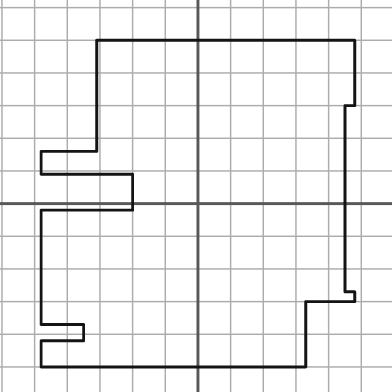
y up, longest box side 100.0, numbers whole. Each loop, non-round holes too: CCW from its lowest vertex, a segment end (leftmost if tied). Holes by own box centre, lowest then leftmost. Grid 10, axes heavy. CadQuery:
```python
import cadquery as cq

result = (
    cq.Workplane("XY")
    .moveTo(-48.0, -50.0)
    .lineTo(33.0, -50.0)
    .lineTo(33.0, -30.0)
    .lineTo(48.0, -30.0)
    .lineTo(48.0, -27.0)
    .lineTo(45.0, -27.0)
    .lineTo(45.0, 30.0)
    .lineTo(48.0, 30.0)
    .lineTo(48.0, 50.0)
    .lineTo(-31.0, 50.0)
    .lineTo(-31.0, 16.0)
    .lineTo(-48.0, 16.0)
    .lineTo(-48.0, 9.0)
    .lineTo(-20.0, 9.0)
    .lineTo(-20.0, -2.0)
    .lineTo(-48.0, -2.0)
    .lineTo(-48.0, -37.0)
    .lineTo(-35.0, -37.0)
    .lineTo(-35.0, -42.0)
    .lineTo(-48.0, -42.0)
    .close()
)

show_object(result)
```